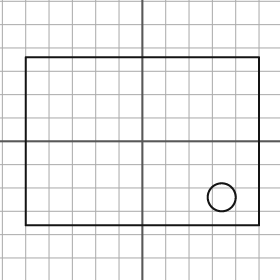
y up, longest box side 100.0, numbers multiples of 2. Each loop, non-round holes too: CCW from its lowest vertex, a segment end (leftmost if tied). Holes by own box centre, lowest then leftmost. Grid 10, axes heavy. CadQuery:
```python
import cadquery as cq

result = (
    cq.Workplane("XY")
    .moveTo(-50.0, -36.0)
    .lineTo(50.0, -36.0)
    .lineTo(50.0, 36.0)
    .lineTo(-50.0, 36.0)
    .close()
    .moveTo(34.0, -24.0)
    .circle(6.0)
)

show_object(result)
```